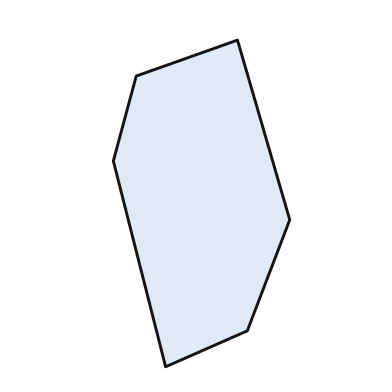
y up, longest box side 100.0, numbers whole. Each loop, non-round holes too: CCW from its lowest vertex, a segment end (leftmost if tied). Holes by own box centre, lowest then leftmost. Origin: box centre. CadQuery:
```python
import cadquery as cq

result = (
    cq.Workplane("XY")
    .moveTo(-11.0, -50.0)
    .lineTo(14.0, -39.0)
    .lineTo(27.0, -5.0)
    .lineTo(11.0, 50.0)
    .lineTo(-20.0, 39.0)
    .lineTo(-27.0, 13.0)
    .close()
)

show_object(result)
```